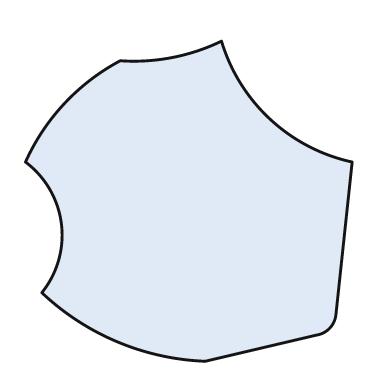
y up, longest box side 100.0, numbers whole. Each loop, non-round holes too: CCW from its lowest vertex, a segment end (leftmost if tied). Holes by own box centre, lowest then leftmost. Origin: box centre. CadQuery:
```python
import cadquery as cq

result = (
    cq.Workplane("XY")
    .moveTo(5.0, -49.0)
    .lineTo(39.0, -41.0)
    .threePointArc((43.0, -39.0), (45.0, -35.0))
    .lineTo(50.0, 12.0)
    .threePointArc((25.0, 25.0), (10.0, 49.0))
    .threePointArc((-5.0, 44.0), (-21.0, 43.0))
    .threePointArc((-38.0, 30.0), (-50.0, 12.0))
    .threePointArc((-39.0, -7.0), (-45.0, -28.0))
    .threePointArc((-22.0, -43.0), (5.0, -49.0))
    .close()
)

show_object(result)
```